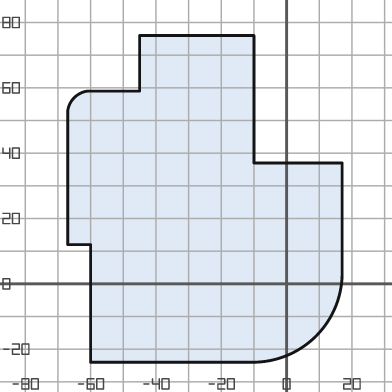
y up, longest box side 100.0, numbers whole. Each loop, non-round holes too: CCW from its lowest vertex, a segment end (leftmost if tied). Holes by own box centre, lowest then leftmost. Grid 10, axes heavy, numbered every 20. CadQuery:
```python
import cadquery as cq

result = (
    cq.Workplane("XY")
    .moveTo(-60.0, -24.0)
    .lineTo(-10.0, -24.0)
    .threePointArc((9.0, -16.0), (17.0, 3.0))
    .lineTo(17.0, 37.0)
    .lineTo(-10.0, 37.0)
    .lineTo(-10.0, 76.0)
    .lineTo(-45.0, 76.0)
    .lineTo(-45.0, 59.0)
    .lineTo(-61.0, 59.0)
    .threePointArc((-65.0, 57.0), (-67.0, 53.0))
    .lineTo(-67.0, 12.0)
    .lineTo(-60.0, 12.0)
    .close()
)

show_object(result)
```